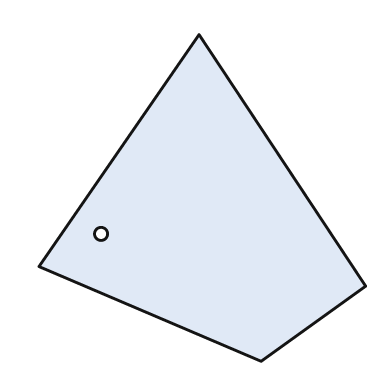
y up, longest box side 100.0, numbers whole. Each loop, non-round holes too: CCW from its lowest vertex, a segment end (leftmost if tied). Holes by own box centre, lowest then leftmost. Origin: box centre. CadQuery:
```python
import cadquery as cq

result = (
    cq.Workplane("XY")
    .moveTo(18.0, -50.0)
    .lineTo(50.0, -27.0)
    .lineTo(-1.0, 50.0)
    .lineTo(-50.0, -21.0)
    .close()
    .moveTo(-31.0, -11.0)
    .circle(2.0)
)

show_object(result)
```